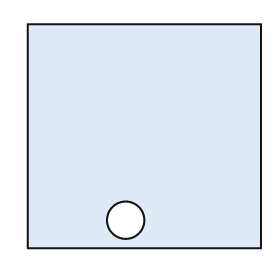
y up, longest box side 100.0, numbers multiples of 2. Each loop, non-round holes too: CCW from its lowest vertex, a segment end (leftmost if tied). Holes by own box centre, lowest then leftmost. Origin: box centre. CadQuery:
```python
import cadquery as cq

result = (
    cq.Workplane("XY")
    .moveTo(-50.0, -48.0)
    .lineTo(50.0, -48.0)
    .lineTo(50.0, 48.0)
    .lineTo(-50.0, 48.0)
    .close()
    .moveTo(-8.0, -36.0)
    .circle(8.0)
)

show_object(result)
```